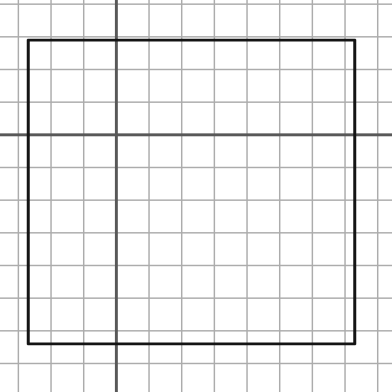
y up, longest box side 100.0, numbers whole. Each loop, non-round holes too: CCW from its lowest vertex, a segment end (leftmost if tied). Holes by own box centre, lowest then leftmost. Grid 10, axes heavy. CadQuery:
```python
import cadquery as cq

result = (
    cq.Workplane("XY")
    .moveTo(-27.0, -64.0)
    .lineTo(73.0, -64.0)
    .lineTo(73.0, 29.0)
    .lineTo(-27.0, 29.0)
    .close()
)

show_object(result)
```